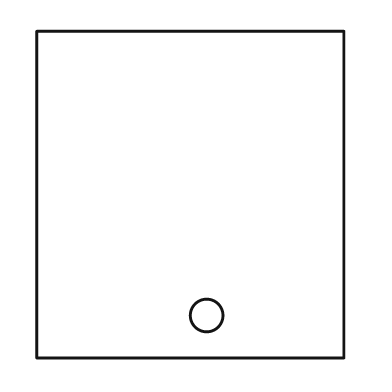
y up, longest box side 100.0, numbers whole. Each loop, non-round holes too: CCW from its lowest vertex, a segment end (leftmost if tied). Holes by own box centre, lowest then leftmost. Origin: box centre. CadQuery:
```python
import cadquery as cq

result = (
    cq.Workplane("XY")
    .moveTo(-47.0, -50.0)
    .lineTo(47.0, -50.0)
    .lineTo(47.0, 50.0)
    .lineTo(-47.0, 50.0)
    .close()
    .moveTo(5.0, -37.0)
    .circle(5.0)
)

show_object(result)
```